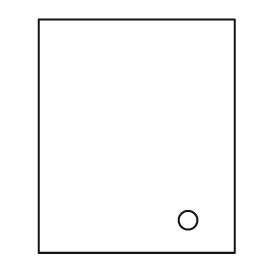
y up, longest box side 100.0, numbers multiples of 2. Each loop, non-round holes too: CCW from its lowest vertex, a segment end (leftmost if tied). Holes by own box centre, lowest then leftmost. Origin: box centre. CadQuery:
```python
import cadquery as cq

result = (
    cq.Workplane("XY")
    .moveTo(-42.0, -50.0)
    .lineTo(42.0, -50.0)
    .lineTo(42.0, 50.0)
    .lineTo(-42.0, 50.0)
    .close()
    .moveTo(22.0, -36.0)
    .circle(4.0)
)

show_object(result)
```